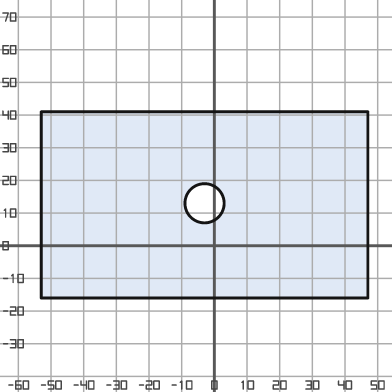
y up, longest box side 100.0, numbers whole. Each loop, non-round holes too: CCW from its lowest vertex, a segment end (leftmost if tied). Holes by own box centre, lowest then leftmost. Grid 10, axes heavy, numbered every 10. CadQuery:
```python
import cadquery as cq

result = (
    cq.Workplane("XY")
    .moveTo(-53.0, -16.0)
    .lineTo(47.0, -16.0)
    .lineTo(47.0, 41.0)
    .lineTo(-53.0, 41.0)
    .close()
    .moveTo(-3.0, 13.0)
    .circle(6.0)
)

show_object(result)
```